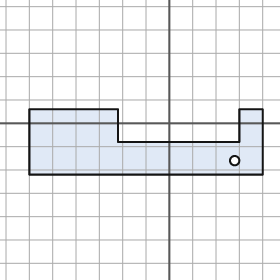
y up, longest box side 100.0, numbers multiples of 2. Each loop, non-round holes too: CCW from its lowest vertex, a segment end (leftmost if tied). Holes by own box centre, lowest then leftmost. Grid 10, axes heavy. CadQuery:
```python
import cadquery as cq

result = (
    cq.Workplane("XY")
    .moveTo(-60.0, -22.0)
    .lineTo(40.0, -22.0)
    .lineTo(40.0, 6.0)
    .lineTo(30.0, 6.0)
    .lineTo(30.0, -8.0)
    .lineTo(-22.0, -8.0)
    .lineTo(-22.0, 6.0)
    .lineTo(-60.0, 6.0)
    .close()
    .moveTo(28.0, -16.0)
    .circle(2.0)
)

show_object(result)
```